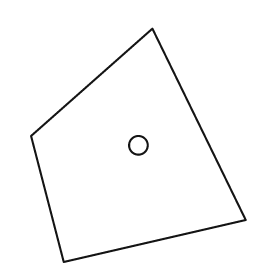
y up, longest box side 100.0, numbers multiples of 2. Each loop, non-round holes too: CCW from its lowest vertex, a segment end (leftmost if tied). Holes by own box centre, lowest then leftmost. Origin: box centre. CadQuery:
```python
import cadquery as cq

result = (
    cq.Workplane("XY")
    .moveTo(-32.0, -50.0)
    .lineTo(46.0, -32.0)
    .lineTo(6.0, 50.0)
    .lineTo(-46.0, 4.0)
    .close()
    .moveTo(0.0, 0.0)
    .circle(4.0)
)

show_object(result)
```